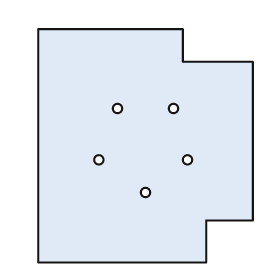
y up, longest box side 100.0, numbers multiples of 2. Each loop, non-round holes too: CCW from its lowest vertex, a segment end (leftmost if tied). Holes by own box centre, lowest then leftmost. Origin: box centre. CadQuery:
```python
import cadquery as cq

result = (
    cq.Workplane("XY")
    .moveTo(-46.0, -50.0)
    .lineTo(26.0, -50.0)
    .lineTo(26.0, -32.0)
    .lineTo(46.0, -32.0)
    .lineTo(46.0, 36.0)
    .lineTo(16.0, 36.0)
    .lineTo(16.0, 50.0)
    .lineTo(-46.0, 50.0)
    .close()
    .moveTo(0.0, -20.0)
    .circle(2.0)
    .moveTo(-20.0, -6.0)
    .circle(2.0)
    .moveTo(18.0, -6.0)
    .circle(2.0)
    .moveTo(-12.0, 16.0)
    .circle(2.0)
    .moveTo(12.0, 16.0)
    .circle(2.0)
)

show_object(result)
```